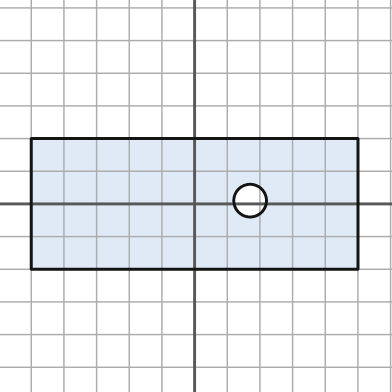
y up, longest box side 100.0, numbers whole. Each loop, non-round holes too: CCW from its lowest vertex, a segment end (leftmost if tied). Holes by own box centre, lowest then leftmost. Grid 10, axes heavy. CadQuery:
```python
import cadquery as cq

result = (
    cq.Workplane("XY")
    .moveTo(-50.0, -20.0)
    .lineTo(50.0, -20.0)
    .lineTo(50.0, 20.0)
    .lineTo(-50.0, 20.0)
    .close()
    .moveTo(17.0, 1.0)
    .circle(5.0)
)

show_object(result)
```